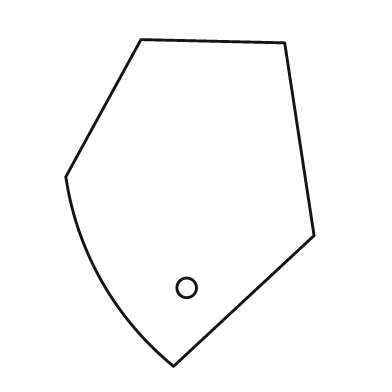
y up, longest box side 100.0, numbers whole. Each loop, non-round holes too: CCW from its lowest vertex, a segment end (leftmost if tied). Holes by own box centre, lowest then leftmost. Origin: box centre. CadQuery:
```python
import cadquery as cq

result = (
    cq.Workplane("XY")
    .moveTo(-5.0, -50.0)
    .lineTo(38.0, -10.0)
    .lineTo(29.0, 49.0)
    .lineTo(-15.0, 50.0)
    .lineTo(-38.0, 8.0)
    .threePointArc((-27.0, -24.0), (-5.0, -50.0))
    .close()
    .moveTo(-1.0, -26.0)
    .circle(3.0)
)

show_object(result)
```